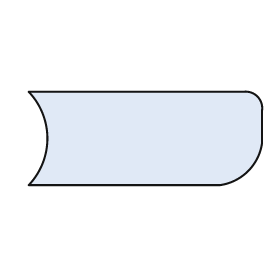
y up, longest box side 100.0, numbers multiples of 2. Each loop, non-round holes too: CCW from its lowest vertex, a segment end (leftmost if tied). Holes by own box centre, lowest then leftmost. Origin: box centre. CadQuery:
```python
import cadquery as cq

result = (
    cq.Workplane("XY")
    .moveTo(-50.0, -20.0)
    .lineTo(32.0, -20.0)
    .threePointArc((44.0, -14.0), (50.0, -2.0))
    .lineTo(50.0, 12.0)
    .threePointArc((48.0, 18.0), (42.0, 20.0))
    .lineTo(-50.0, 20.0)
    .threePointArc((-42.0, 0.0), (-50.0, -20.0))
    .close()
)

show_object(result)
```